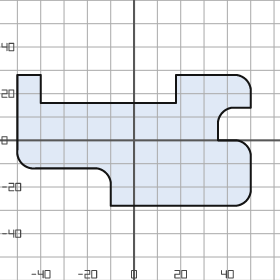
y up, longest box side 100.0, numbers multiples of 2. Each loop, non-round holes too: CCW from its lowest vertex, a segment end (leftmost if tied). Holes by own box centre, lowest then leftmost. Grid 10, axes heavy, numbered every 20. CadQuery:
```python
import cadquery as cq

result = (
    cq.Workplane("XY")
    .moveTo(-10.0, -28.0)
    .lineTo(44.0, -28.0)
    .threePointArc((48.0, -26.0), (50.0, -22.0))
    .lineTo(50.0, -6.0)
    .threePointArc((48.0, -2.0), (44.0, 0.0))
    .lineTo(36.0, 0.0)
    .lineTo(36.0, 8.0)
    .threePointArc((38.0, 12.0), (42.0, 14.0))
    .lineTo(50.0, 14.0)
    .lineTo(50.0, 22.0)
    .threePointArc((48.0, 26.0), (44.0, 28.0))
    .lineTo(18.0, 28.0)
    .lineTo(18.0, 16.0)
    .lineTo(-40.0, 16.0)
    .lineTo(-40.0, 28.0)
    .lineTo(-50.0, 28.0)
    .lineTo(-50.0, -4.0)
    .threePointArc((-48.0, -10.0), (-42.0, -12.0))
    .lineTo(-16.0, -12.0)
    .threePointArc((-12.0, -14.0), (-10.0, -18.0))
    .close()
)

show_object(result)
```